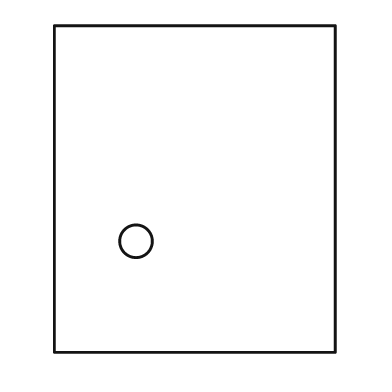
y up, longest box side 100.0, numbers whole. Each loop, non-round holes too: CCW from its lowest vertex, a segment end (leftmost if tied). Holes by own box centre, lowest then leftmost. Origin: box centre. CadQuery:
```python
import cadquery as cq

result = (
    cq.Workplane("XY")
    .moveTo(-43.0, -50.0)
    .lineTo(43.0, -50.0)
    .lineTo(43.0, 50.0)
    .lineTo(-43.0, 50.0)
    .close()
    .moveTo(-18.0, -16.0)
    .circle(5.0)
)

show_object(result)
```